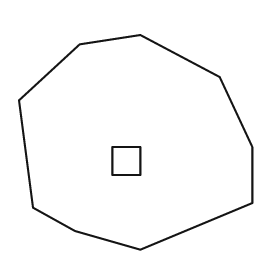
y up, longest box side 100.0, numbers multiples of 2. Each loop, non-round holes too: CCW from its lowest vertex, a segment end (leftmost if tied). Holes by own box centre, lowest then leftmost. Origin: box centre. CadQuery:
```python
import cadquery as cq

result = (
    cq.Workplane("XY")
    .moveTo(2.0, -46.0)
    .lineTo(50.0, -26.0)
    .lineTo(50.0, -2.0)
    .lineTo(36.0, 28.0)
    .lineTo(2.0, 46.0)
    .lineTo(-24.0, 42.0)
    .lineTo(-50.0, 18.0)
    .lineTo(-44.0, -28.0)
    .lineTo(-26.0, -38.0)
    .close()
    .moveTo(-10.0, -14.0)
    .lineTo(2.0, -14.0)
    .lineTo(2.0, -2.0)
    .lineTo(-10.0, -2.0)
    .close()
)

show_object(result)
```